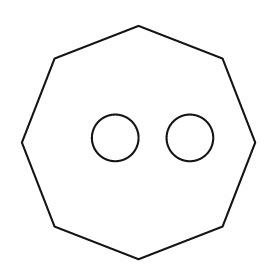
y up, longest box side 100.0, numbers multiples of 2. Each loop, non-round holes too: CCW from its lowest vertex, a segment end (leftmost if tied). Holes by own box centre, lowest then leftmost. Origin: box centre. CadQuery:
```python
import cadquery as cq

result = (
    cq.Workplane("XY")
    .moveTo(0.0, -50.0)
    .lineTo(36.0, -36.0)
    .lineTo(50.0, 0.0)
    .lineTo(36.0, 36.0)
    .lineTo(0.0, 50.0)
    .lineTo(-36.0, 36.0)
    .lineTo(-50.0, 0.0)
    .lineTo(-36.0, -36.0)
    .close()
    .moveTo(-10.0, 2.0)
    .circle(10.0)
    .moveTo(22.0, 2.0)
    .circle(10.0)
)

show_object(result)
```